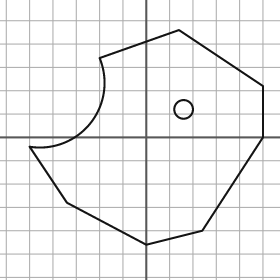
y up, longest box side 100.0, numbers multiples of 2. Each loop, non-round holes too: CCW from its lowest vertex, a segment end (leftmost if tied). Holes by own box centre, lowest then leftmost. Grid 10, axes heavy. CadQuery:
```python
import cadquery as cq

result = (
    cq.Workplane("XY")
    .moveTo(0.0, -46.0)
    .lineTo(24.0, -40.0)
    .lineTo(50.0, 0.0)
    .lineTo(50.0, 22.0)
    .lineTo(14.0, 46.0)
    .lineTo(-20.0, 34.0)
    .threePointArc((-24.0, 6.0), (-50.0, -4.0))
    .lineTo(-34.0, -28.0)
    .close()
    .moveTo(16.0, 12.0)
    .circle(4.0)
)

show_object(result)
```